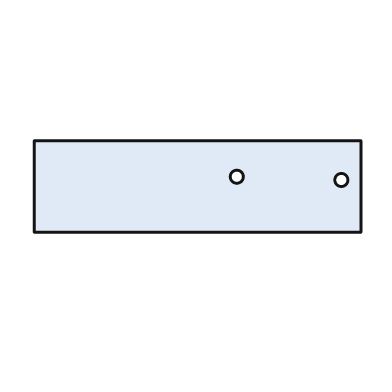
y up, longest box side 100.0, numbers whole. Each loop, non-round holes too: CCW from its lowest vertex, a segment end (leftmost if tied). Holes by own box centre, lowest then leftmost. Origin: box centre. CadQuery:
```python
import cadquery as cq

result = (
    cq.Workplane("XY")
    .moveTo(-50.0, -14.0)
    .lineTo(50.0, -14.0)
    .lineTo(50.0, 14.0)
    .lineTo(-50.0, 14.0)
    .close()
    .moveTo(44.0, 2.0)
    .circle(2.0)
    .moveTo(12.0, 3.0)
    .circle(2.0)
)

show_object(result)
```